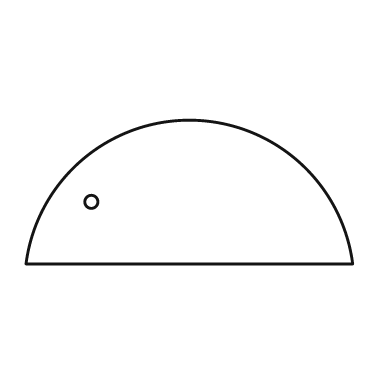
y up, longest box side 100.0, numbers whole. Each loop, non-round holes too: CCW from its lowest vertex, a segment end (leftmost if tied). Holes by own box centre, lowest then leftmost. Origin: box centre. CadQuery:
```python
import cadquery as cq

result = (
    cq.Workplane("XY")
    .moveTo(-50.0, -22.0)
    .lineTo(50.0, -22.0)
    .threePointArc((0.0, 22.0), (-50.0, -22.0))
    .close()
    .moveTo(-30.0, -3.0)
    .circle(2.0)
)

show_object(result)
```